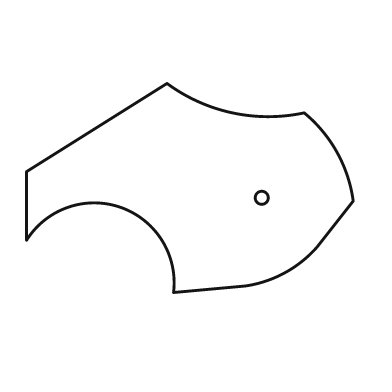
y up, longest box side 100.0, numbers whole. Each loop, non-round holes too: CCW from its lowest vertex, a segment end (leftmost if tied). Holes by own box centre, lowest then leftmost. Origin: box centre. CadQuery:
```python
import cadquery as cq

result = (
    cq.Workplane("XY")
    .moveTo(-5.0, -32.0)
    .lineTo(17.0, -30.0)
    .threePointArc((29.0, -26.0), (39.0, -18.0))
    .lineTo(50.0, -4.0)
    .threePointArc((45.0, 11.0), (35.0, 23.0))
    .threePointArc((13.0, 23.0), (-7.0, 32.0))
    .lineTo(-50.0, 5.0)
    .lineTo(-50.0, -16.0)
    .threePointArc((-21.0, -6.0), (-5.0, -32.0))
    .close()
    .moveTo(22.0, -3.0)
    .circle(2.0)
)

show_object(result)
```